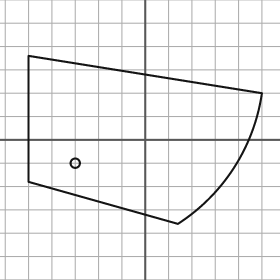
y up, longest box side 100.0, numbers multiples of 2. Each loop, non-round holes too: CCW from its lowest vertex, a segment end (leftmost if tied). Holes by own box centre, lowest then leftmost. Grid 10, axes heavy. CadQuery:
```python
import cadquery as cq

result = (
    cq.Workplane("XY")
    .moveTo(14.0, -36.0)
    .threePointArc((38.0, -12.0), (50.0, 20.0))
    .lineTo(-50.0, 36.0)
    .lineTo(-50.0, -18.0)
    .close()
    .moveTo(-30.0, -10.0)
    .circle(2.0)
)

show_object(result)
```